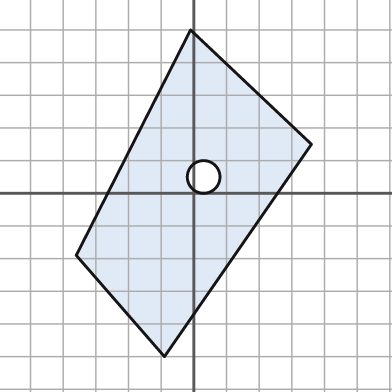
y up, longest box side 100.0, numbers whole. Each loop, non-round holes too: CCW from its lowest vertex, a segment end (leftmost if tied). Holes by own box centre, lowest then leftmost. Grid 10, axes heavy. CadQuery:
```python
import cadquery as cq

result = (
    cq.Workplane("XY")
    .moveTo(-9.0, -50.0)
    .lineTo(36.0, 15.0)
    .lineTo(-1.0, 50.0)
    .lineTo(-36.0, -19.0)
    .close()
    .moveTo(3.0, 5.0)
    .circle(5.0)
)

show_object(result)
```